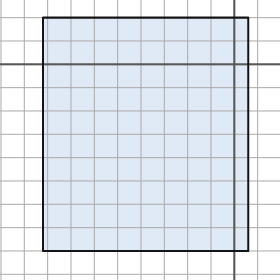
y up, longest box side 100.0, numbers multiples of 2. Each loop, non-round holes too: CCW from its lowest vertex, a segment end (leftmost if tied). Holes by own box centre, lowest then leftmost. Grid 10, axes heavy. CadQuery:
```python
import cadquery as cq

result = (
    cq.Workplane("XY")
    .moveTo(-82.0, -80.0)
    .lineTo(6.0, -80.0)
    .lineTo(6.0, 20.0)
    .lineTo(-82.0, 20.0)
    .close()
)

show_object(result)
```